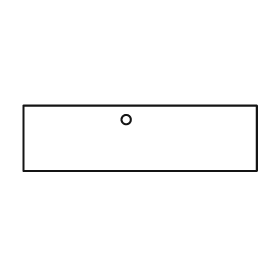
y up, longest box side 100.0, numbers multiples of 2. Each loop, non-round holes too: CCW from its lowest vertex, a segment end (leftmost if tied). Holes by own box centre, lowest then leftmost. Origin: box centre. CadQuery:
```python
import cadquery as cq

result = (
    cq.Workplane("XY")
    .moveTo(-50.0, -14.0)
    .lineTo(50.0, -14.0)
    .lineTo(50.0, 14.0)
    .lineTo(-50.0, 14.0)
    .close()
    .moveTo(-6.0, 8.0)
    .circle(2.0)
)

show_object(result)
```